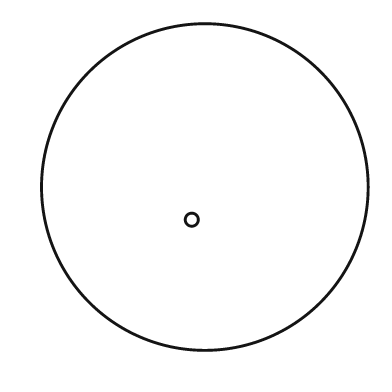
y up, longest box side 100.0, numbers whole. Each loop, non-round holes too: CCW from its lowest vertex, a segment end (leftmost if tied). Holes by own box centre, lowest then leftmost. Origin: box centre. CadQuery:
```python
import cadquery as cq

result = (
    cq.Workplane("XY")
    .moveTo(0.0, 0.0)
    .circle(50.0)
    .moveTo(-4.0, -10.0)
    .circle(2.0)
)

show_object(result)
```